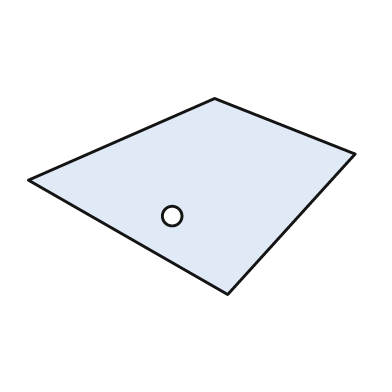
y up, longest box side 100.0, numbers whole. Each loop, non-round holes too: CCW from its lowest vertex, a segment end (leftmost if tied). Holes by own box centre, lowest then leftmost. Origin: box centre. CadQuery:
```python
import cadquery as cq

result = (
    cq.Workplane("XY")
    .moveTo(11.0, -30.0)
    .lineTo(50.0, 13.0)
    .lineTo(7.0, 30.0)
    .lineTo(-50.0, 5.0)
    .close()
    .moveTo(-6.0, -6.0)
    .circle(3.0)
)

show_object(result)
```